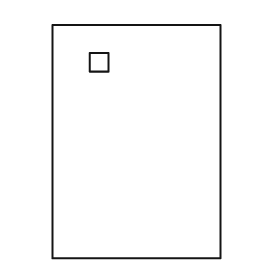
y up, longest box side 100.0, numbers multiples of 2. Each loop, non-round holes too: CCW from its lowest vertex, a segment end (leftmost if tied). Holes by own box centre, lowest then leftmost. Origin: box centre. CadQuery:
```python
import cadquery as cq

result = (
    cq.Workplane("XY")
    .moveTo(-36.0, -50.0)
    .lineTo(36.0, -50.0)
    .lineTo(36.0, 50.0)
    .lineTo(-36.0, 50.0)
    .close()
    .moveTo(-20.0, 30.0)
    .lineTo(-12.0, 30.0)
    .lineTo(-12.0, 38.0)
    .lineTo(-20.0, 38.0)
    .close()
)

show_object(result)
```